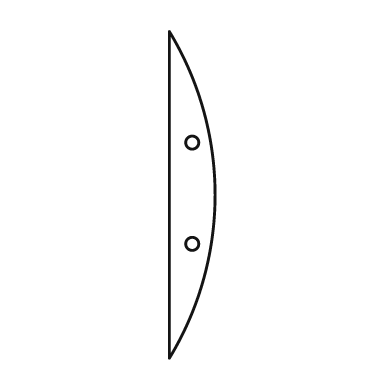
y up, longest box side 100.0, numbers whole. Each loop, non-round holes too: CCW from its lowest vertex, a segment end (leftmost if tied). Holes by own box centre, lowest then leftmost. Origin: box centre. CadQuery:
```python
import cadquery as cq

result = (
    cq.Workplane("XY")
    .moveTo(-7.0, -50.0)
    .threePointArc((7.0, 0.0), (-7.0, 50.0))
    .close()
    .moveTo(0.0, -15.0)
    .circle(2.0)
    .moveTo(0.0, 16.0)
    .circle(2.0)
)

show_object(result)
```